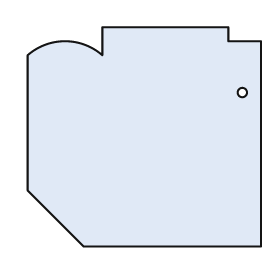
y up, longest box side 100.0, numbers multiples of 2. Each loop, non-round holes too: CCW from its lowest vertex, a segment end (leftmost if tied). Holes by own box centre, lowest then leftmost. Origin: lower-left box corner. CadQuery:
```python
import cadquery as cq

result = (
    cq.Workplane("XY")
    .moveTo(24.0, 0.0)
    .lineTo(100.0, 0.0)
    .lineTo(100.0, 88.0)
    .lineTo(86.0, 88.0)
    .lineTo(86.0, 94.0)
    .lineTo(32.0, 94.0)
    .lineTo(32.0, 82.0)
    .threePointArc((16.0, 88.0), (0.0, 82.0))
    .lineTo(0.0, 24.0)
    .close()
    .moveTo(92.0, 66.0)
    .circle(2.0)
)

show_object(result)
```